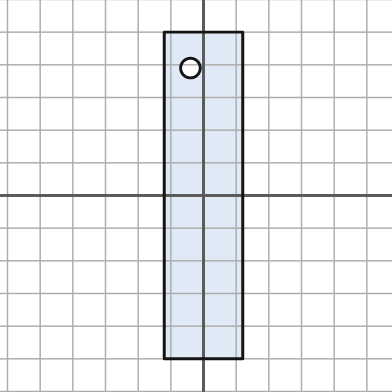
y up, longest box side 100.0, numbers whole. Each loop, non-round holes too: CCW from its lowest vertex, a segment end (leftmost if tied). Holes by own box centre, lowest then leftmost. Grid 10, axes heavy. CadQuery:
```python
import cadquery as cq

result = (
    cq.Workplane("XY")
    .moveTo(-12.0, -50.0)
    .lineTo(12.0, -50.0)
    .lineTo(12.0, 50.0)
    .lineTo(-12.0, 50.0)
    .close()
    .moveTo(-4.0, 39.0)
    .circle(3.0)
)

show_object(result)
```